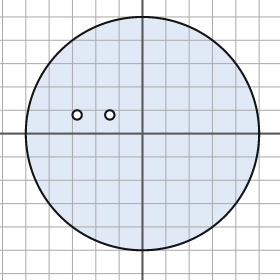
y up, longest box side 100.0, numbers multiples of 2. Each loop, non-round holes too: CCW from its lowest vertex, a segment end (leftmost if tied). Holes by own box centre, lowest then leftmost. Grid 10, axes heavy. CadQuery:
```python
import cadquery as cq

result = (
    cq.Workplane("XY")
    .moveTo(0.0, 0.0)
    .circle(50.0)
    .moveTo(-28.0, 8.0)
    .circle(2.0)
    .moveTo(-14.0, 8.0)
    .circle(2.0)
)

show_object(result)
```